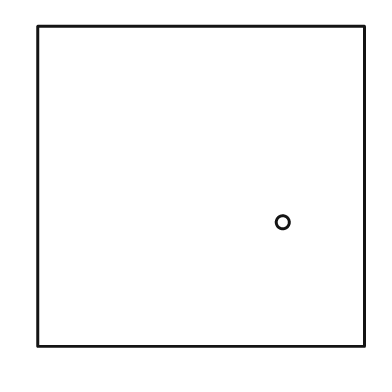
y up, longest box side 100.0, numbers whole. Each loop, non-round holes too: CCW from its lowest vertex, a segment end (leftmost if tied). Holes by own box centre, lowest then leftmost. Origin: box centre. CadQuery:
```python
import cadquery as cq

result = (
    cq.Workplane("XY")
    .moveTo(-50.0, -49.0)
    .lineTo(50.0, -49.0)
    .lineTo(50.0, 49.0)
    .lineTo(-50.0, 49.0)
    .close()
    .moveTo(25.0, -11.0)
    .circle(2.0)
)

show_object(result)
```